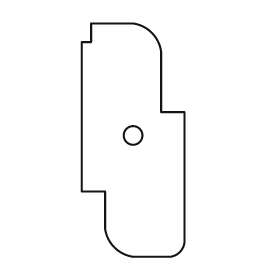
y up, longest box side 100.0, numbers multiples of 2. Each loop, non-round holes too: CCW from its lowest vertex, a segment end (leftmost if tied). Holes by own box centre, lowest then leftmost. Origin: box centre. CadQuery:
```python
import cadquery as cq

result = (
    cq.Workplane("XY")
    .moveTo(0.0, -50.0)
    .lineTo(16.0, -50.0)
    .threePointArc((20.0, -48.0), (22.0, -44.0))
    .lineTo(22.0, 12.0)
    .lineTo(12.0, 12.0)
    .lineTo(12.0, 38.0)
    .threePointArc((8.0, 46.0), (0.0, 50.0))
    .lineTo(-18.0, 50.0)
    .lineTo(-18.0, 42.0)
    .lineTo(-22.0, 42.0)
    .lineTo(-22.0, -22.0)
    .lineTo(-12.0, -22.0)
    .lineTo(-12.0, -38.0)
    .threePointArc((-8.0, -46.0), (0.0, -50.0))
    .close()
    .moveTo(0.0, 2.0)
    .circle(4.0)
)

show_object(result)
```